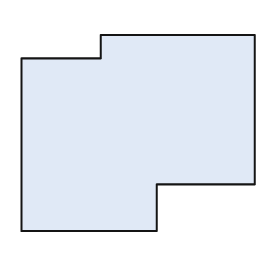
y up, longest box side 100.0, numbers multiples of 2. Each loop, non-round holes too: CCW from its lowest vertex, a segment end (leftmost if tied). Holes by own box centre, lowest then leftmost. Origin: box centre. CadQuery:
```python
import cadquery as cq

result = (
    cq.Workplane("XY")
    .moveTo(-50.0, -42.0)
    .lineTo(8.0, -42.0)
    .lineTo(8.0, -22.0)
    .lineTo(50.0, -22.0)
    .lineTo(50.0, 42.0)
    .lineTo(-16.0, 42.0)
    .lineTo(-16.0, 32.0)
    .lineTo(-50.0, 32.0)
    .close()
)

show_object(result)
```